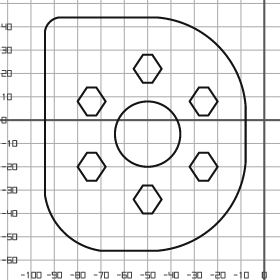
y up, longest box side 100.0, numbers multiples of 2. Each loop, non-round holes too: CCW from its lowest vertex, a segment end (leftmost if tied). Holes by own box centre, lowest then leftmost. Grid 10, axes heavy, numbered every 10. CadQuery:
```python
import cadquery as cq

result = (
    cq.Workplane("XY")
    .moveTo(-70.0, -56.0)
    .lineTo(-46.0, -56.0)
    .threePointArc((-20.0, -44.0), (-8.0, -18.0))
    .lineTo(-8.0, 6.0)
    .threePointArc((-20.0, 32.0), (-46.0, 44.0))
    .lineTo(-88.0, 44.0)
    .threePointArc((-92.0, 42.0), (-94.0, 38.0))
    .lineTo(-94.0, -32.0)
    .threePointArc((-86.0, -48.0), (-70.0, -56.0))
    .close()
    .moveTo(-52.0, -40.0)
    .lineTo(-48.0, -40.0)
    .lineTo(-44.0, -34.0)
    .lineTo(-48.0, -28.0)
    .lineTo(-52.0, -28.0)
    .lineTo(-56.0, -34.0)
    .close()
    .moveTo(-76.0, -26.0)
    .lineTo(-72.0, -26.0)
    .lineTo(-68.0, -20.0)
    .lineTo(-72.0, -14.0)
    .lineTo(-76.0, -14.0)
    .lineTo(-80.0, -20.0)
    .close()
    .moveTo(-28.0, -26.0)
    .lineTo(-24.0, -26.0)
    .lineTo(-20.0, -20.0)
    .lineTo(-24.0, -14.0)
    .lineTo(-28.0, -14.0)
    .lineTo(-32.0, -20.0)
    .close()
    .moveTo(-50.0, -6.0)
    .circle(14.0)
    .moveTo(-76.0, 2.0)
    .lineTo(-72.0, 2.0)
    .lineTo(-68.0, 8.0)
    .lineTo(-72.0, 14.0)
    .lineTo(-76.0, 14.0)
    .lineTo(-80.0, 8.0)
    .close()
    .moveTo(-28.0, 2.0)
    .lineTo(-24.0, 2.0)
    .lineTo(-20.0, 8.0)
    .lineTo(-24.0, 14.0)
    .lineTo(-28.0, 14.0)
    .lineTo(-32.0, 8.0)
    .close()
    .moveTo(-52.0, 16.0)
    .lineTo(-48.0, 16.0)
    .lineTo(-44.0, 22.0)
    .lineTo(-48.0, 28.0)
    .lineTo(-52.0, 28.0)
    .lineTo(-56.0, 22.0)
    .close()
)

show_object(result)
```